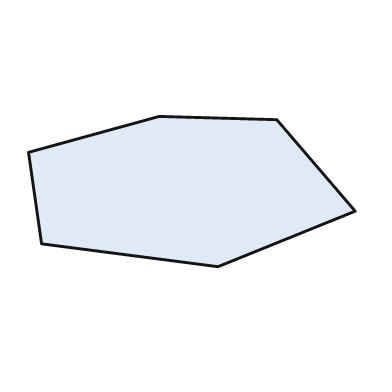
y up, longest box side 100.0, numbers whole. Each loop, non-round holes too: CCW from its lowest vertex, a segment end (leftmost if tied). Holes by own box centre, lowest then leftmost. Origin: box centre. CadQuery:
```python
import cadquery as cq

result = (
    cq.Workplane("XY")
    .moveTo(8.0, -23.0)
    .lineTo(50.0, -6.0)
    .lineTo(26.0, 22.0)
    .lineTo(-10.0, 23.0)
    .lineTo(-50.0, 12.0)
    .lineTo(-46.0, -16.0)
    .close()
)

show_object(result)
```